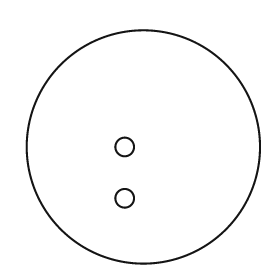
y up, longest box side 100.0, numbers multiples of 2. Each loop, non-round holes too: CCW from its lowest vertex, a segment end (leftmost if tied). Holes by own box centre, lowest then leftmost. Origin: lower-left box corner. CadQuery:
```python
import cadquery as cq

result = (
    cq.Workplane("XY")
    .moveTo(50.0, 50.0)
    .circle(50.0)
    .moveTo(42.0, 28.0)
    .circle(4.0)
    .moveTo(42.0, 50.0)
    .circle(4.0)
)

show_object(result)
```